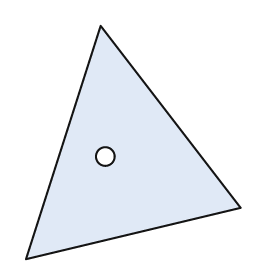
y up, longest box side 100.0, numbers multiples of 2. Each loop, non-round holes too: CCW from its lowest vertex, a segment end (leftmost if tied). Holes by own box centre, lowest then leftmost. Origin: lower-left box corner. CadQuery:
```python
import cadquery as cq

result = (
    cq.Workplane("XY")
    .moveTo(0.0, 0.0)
    .lineTo(92.0, 22.0)
    .lineTo(32.0, 100.0)
    .close()
    .moveTo(34.0, 44.0)
    .circle(4.0)
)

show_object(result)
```